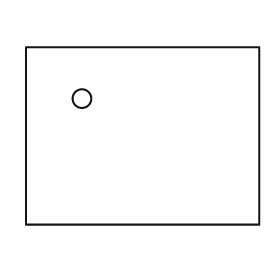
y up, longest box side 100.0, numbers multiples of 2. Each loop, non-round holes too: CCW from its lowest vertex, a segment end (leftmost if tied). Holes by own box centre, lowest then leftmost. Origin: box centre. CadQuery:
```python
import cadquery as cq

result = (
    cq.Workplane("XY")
    .moveTo(-50.0, -38.0)
    .lineTo(50.0, -38.0)
    .lineTo(50.0, 38.0)
    .lineTo(-50.0, 38.0)
    .close()
    .moveTo(-26.0, 16.0)
    .circle(4.0)
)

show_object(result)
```